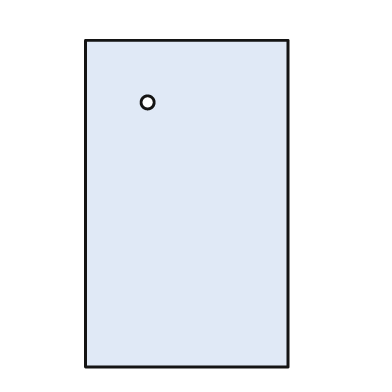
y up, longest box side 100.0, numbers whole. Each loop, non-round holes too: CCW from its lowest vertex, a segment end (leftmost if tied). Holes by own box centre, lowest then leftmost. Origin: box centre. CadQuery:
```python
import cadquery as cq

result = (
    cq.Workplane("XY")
    .moveTo(-31.0, -50.0)
    .lineTo(31.0, -50.0)
    .lineTo(31.0, 50.0)
    .lineTo(-31.0, 50.0)
    .close()
    .moveTo(-12.0, 31.0)
    .circle(2.0)
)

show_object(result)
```